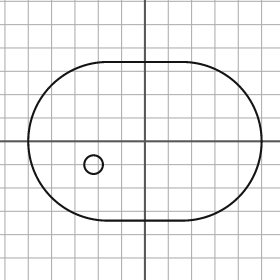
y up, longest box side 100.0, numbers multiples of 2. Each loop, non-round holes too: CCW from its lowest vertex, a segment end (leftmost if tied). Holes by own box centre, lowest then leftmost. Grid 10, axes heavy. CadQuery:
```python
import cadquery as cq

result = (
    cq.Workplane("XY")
    .moveTo(-16.0, -34.0)
    .lineTo(16.0, -34.0)
    .threePointArc((50.0, 0.0), (16.0, 34.0))
    .lineTo(-16.0, 34.0)
    .threePointArc((-50.0, 0.0), (-16.0, -34.0))
    .close()
    .moveTo(-22.0, -10.0)
    .circle(4.0)
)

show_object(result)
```